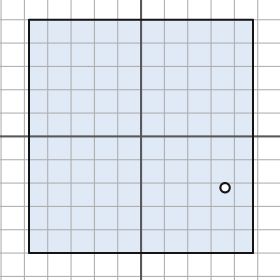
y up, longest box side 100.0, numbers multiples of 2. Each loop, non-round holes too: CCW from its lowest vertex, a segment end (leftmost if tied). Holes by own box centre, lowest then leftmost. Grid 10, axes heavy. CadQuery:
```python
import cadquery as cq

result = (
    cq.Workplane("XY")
    .moveTo(-48.0, -50.0)
    .lineTo(48.0, -50.0)
    .lineTo(48.0, 50.0)
    .lineTo(-48.0, 50.0)
    .close()
    .moveTo(36.0, -22.0)
    .circle(2.0)
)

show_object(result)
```